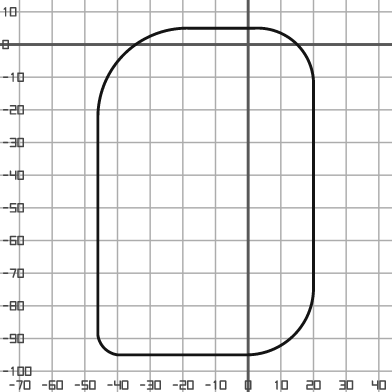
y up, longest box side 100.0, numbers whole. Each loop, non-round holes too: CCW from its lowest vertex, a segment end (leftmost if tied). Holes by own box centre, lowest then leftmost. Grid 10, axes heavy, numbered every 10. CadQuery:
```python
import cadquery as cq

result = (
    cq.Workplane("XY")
    .moveTo(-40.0, -95.0)
    .lineTo(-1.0, -95.0)
    .threePointArc((14.0, -89.0), (20.0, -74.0))
    .lineTo(20.0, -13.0)
    .threePointArc((15.0, 0.0), (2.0, 5.0))
    .lineTo(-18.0, 5.0)
    .threePointArc((-38.0, -3.0), (-46.0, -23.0))
    .lineTo(-46.0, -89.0)
    .threePointArc((-44.0, -93.0), (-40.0, -95.0))
    .close()
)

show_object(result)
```